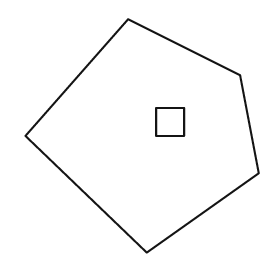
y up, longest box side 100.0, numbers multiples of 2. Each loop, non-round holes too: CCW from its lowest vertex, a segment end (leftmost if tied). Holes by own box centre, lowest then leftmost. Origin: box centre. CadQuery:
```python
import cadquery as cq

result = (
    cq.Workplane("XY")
    .moveTo(2.0, -50.0)
    .lineTo(50.0, -16.0)
    .lineTo(42.0, 26.0)
    .lineTo(-6.0, 50.0)
    .lineTo(-50.0, 0.0)
    .close()
    .moveTo(6.0, 0.0)
    .lineTo(18.0, 0.0)
    .lineTo(18.0, 12.0)
    .lineTo(6.0, 12.0)
    .close()
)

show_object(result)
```